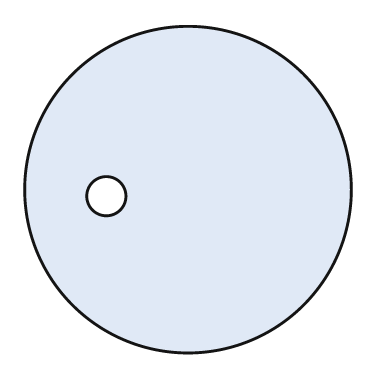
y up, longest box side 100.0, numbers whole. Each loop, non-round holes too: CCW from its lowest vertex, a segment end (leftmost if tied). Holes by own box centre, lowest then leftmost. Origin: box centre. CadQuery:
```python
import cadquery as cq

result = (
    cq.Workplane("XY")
    .moveTo(0.0, 0.0)
    .circle(50.0)
    .moveTo(-25.0, -2.0)
    .circle(6.0)
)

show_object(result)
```